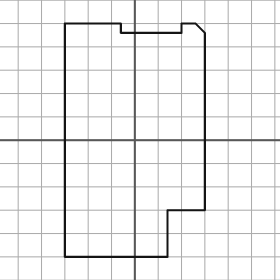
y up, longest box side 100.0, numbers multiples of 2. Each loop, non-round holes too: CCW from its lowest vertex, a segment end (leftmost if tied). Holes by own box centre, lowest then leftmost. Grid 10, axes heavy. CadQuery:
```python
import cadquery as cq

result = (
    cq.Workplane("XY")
    .moveTo(-30.0, -50.0)
    .lineTo(14.0, -50.0)
    .lineTo(14.0, -30.0)
    .lineTo(30.0, -30.0)
    .lineTo(30.0, 46.0)
    .lineTo(26.0, 50.0)
    .lineTo(20.0, 50.0)
    .lineTo(20.0, 46.0)
    .lineTo(-6.0, 46.0)
    .lineTo(-6.0, 50.0)
    .lineTo(-30.0, 50.0)
    .close()
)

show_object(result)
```